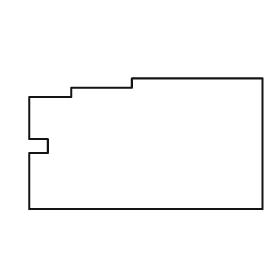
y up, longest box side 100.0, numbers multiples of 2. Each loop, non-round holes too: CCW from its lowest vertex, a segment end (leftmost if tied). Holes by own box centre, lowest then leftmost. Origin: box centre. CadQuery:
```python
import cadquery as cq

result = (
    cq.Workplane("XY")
    .moveTo(-50.0, -28.0)
    .lineTo(50.0, -28.0)
    .lineTo(50.0, 28.0)
    .lineTo(-6.0, 28.0)
    .lineTo(-6.0, 24.0)
    .lineTo(-32.0, 24.0)
    .lineTo(-32.0, 20.0)
    .lineTo(-50.0, 20.0)
    .lineTo(-50.0, 2.0)
    .lineTo(-42.0, 2.0)
    .lineTo(-42.0, -4.0)
    .lineTo(-50.0, -4.0)
    .close()
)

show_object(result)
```